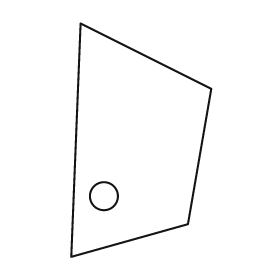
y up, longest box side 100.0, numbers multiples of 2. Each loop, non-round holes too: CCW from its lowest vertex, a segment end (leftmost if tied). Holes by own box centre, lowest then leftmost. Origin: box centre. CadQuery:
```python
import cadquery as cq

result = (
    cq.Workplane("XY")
    .moveTo(-30.0, -50.0)
    .lineTo(20.0, -36.0)
    .lineTo(30.0, 22.0)
    .lineTo(-26.0, 50.0)
    .close()
    .moveTo(-16.0, -24.0)
    .circle(6.0)
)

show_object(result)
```